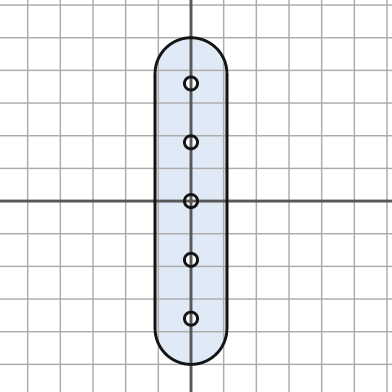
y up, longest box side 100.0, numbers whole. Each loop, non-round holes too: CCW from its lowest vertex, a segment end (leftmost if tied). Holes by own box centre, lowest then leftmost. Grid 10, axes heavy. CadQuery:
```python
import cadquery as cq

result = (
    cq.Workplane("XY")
    .moveTo(-11.0, -39.0)
    .threePointArc((0.0, -50.0), (11.0, -39.0))
    .lineTo(11.0, 39.0)
    .threePointArc((0.0, 50.0), (-11.0, 39.0))
    .close()
    .moveTo(0.0, -36.0)
    .circle(2.0)
    .moveTo(0.0, -18.0)
    .circle(2.0)
    .moveTo(0.0, 0.0)
    .circle(2.0)
    .moveTo(0.0, 18.0)
    .circle(2.0)
    .moveTo(0.0, 36.0)
    .circle(2.0)
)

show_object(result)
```